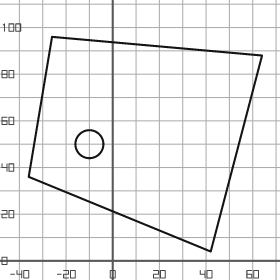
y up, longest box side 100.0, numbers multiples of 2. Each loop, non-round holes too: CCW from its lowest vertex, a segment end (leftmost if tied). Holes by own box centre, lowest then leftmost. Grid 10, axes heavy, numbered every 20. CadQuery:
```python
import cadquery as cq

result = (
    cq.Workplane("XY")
    .moveTo(42.0, 4.0)
    .lineTo(64.0, 88.0)
    .lineTo(-26.0, 96.0)
    .lineTo(-36.0, 36.0)
    .close()
    .moveTo(-10.0, 50.0)
    .circle(6.0)
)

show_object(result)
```